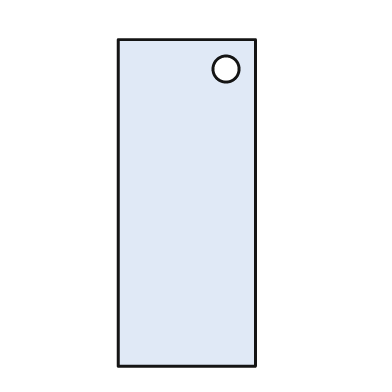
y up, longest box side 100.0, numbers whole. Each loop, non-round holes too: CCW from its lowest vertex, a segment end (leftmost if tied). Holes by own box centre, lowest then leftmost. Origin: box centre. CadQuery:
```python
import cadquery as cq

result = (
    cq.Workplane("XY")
    .moveTo(-21.0, -50.0)
    .lineTo(21.0, -50.0)
    .lineTo(21.0, 50.0)
    .lineTo(-21.0, 50.0)
    .close()
    .moveTo(12.0, 41.0)
    .circle(4.0)
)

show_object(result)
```